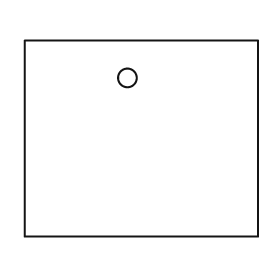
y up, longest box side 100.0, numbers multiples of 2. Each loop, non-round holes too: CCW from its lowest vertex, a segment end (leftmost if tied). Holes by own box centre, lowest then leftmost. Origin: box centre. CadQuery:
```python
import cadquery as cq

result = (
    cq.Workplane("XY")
    .moveTo(-50.0, -42.0)
    .lineTo(50.0, -42.0)
    .lineTo(50.0, 42.0)
    .lineTo(-50.0, 42.0)
    .close()
    .moveTo(-6.0, 26.0)
    .circle(4.0)
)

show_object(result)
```